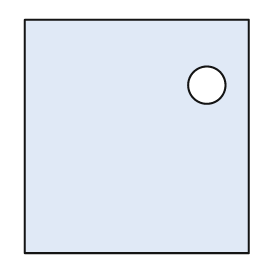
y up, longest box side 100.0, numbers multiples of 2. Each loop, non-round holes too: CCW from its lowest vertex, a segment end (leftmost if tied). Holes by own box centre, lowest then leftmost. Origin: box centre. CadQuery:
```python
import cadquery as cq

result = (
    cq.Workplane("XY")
    .moveTo(-48.0, -50.0)
    .lineTo(48.0, -50.0)
    .lineTo(48.0, 50.0)
    .lineTo(-48.0, 50.0)
    .close()
    .moveTo(30.0, 22.0)
    .circle(8.0)
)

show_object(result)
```